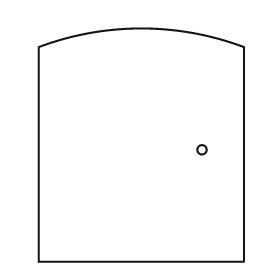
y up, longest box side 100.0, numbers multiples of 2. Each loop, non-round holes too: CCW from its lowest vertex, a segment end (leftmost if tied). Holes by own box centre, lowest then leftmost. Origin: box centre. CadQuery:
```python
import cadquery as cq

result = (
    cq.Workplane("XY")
    .moveTo(-44.0, -50.0)
    .lineTo(44.0, -50.0)
    .lineTo(44.0, 42.0)
    .threePointArc((0.0, 50.0), (-44.0, 42.0))
    .close()
    .moveTo(26.0, -2.0)
    .circle(2.0)
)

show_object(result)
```